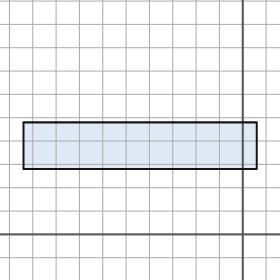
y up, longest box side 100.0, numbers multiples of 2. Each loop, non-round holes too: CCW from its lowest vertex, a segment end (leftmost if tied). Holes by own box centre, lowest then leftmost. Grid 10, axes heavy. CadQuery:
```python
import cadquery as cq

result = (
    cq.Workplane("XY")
    .moveTo(-94.0, 28.0)
    .lineTo(6.0, 28.0)
    .lineTo(6.0, 48.0)
    .lineTo(-94.0, 48.0)
    .close()
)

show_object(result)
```